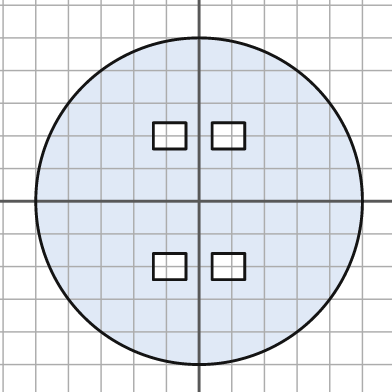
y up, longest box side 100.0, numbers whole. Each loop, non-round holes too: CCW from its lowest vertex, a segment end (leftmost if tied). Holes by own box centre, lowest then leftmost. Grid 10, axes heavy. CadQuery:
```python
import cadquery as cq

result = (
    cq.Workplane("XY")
    .moveTo(0.0, 0.0)
    .circle(50.0)
    .moveTo(-14.0, -24.0)
    .lineTo(-4.0, -24.0)
    .lineTo(-4.0, -16.0)
    .lineTo(-14.0, -16.0)
    .close()
    .moveTo(4.0, -24.0)
    .lineTo(14.0, -24.0)
    .lineTo(14.0, -16.0)
    .lineTo(4.0, -16.0)
    .close()
    .moveTo(-14.0, 16.0)
    .lineTo(-4.0, 16.0)
    .lineTo(-4.0, 24.0)
    .lineTo(-14.0, 24.0)
    .close()
    .moveTo(4.0, 16.0)
    .lineTo(14.0, 16.0)
    .lineTo(14.0, 24.0)
    .lineTo(4.0, 24.0)
    .close()
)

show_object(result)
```